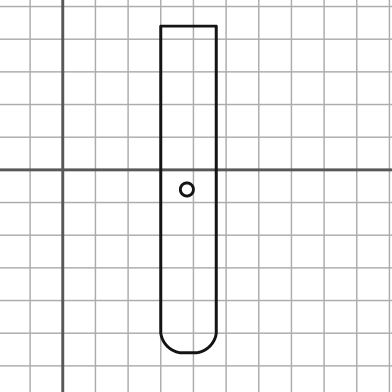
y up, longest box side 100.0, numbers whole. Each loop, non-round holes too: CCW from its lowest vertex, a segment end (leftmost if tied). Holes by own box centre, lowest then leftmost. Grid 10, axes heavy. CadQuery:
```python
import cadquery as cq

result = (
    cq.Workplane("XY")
    .moveTo(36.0, -56.0)
    .lineTo(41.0, -56.0)
    .threePointArc((45.0, -54.0), (47.0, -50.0))
    .lineTo(47.0, 44.0)
    .lineTo(30.0, 44.0)
    .lineTo(30.0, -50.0)
    .threePointArc((32.0, -54.0), (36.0, -56.0))
    .close()
    .moveTo(38.0, -6.0)
    .circle(2.0)
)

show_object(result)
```